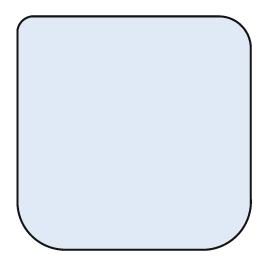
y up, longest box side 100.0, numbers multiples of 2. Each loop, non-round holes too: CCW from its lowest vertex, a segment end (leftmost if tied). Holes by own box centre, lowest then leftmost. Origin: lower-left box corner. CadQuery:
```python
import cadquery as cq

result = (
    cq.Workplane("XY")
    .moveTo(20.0, 0.0)
    .lineTo(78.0, 0.0)
    .threePointArc((94.0, 6.0), (100.0, 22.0))
    .lineTo(100.0, 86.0)
    .threePointArc((96.0, 96.0), (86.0, 100.0))
    .lineTo(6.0, 100.0)
    .threePointArc((2.0, 98.0), (0.0, 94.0))
    .lineTo(0.0, 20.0)
    .threePointArc((6.0, 6.0), (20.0, 0.0))
    .close()
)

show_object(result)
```